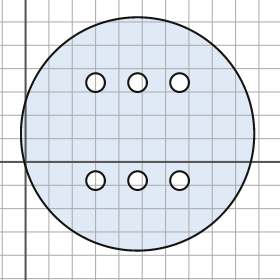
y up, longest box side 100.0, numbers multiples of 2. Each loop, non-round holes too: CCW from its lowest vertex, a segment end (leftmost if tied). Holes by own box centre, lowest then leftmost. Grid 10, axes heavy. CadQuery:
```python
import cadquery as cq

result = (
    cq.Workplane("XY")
    .moveTo(48.0, 12.0)
    .circle(50.0)
    .moveTo(30.0, -8.0)
    .circle(4.0)
    .moveTo(48.0, -8.0)
    .circle(4.0)
    .moveTo(66.0, -8.0)
    .circle(4.0)
    .moveTo(30.0, 34.0)
    .circle(4.0)
    .moveTo(48.0, 34.0)
    .circle(4.0)
    .moveTo(66.0, 34.0)
    .circle(4.0)
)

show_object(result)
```